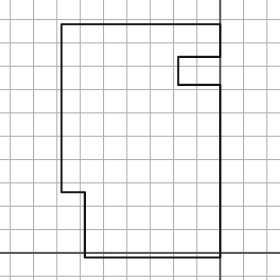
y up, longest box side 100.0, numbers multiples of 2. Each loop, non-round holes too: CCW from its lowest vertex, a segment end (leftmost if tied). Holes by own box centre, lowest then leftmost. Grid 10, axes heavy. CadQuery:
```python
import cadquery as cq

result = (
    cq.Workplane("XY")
    .moveTo(-58.0, -2.0)
    .lineTo(0.0, -2.0)
    .lineTo(0.0, 72.0)
    .lineTo(-18.0, 72.0)
    .lineTo(-18.0, 84.0)
    .lineTo(0.0, 84.0)
    .lineTo(0.0, 98.0)
    .lineTo(-68.0, 98.0)
    .lineTo(-68.0, 26.0)
    .lineTo(-58.0, 26.0)
    .close()
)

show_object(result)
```